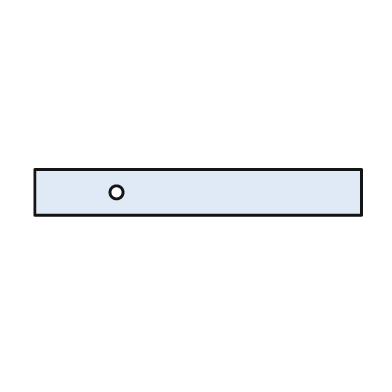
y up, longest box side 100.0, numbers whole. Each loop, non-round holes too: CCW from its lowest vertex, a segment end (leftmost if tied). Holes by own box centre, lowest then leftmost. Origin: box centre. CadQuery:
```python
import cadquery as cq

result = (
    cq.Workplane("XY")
    .moveTo(-50.0, -7.0)
    .lineTo(50.0, -7.0)
    .lineTo(50.0, 7.0)
    .lineTo(-50.0, 7.0)
    .close()
    .moveTo(-25.0, 0.0)
    .circle(2.0)
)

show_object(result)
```